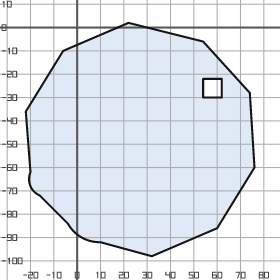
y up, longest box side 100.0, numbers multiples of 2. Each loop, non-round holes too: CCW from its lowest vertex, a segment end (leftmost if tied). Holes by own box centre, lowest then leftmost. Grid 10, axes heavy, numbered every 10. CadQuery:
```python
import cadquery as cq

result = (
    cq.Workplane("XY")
    .moveTo(32.0, -98.0)
    .lineTo(60.0, -86.0)
    .lineTo(76.0, -60.0)
    .lineTo(74.0, -28.0)
    .lineTo(54.0, -6.0)
    .lineTo(22.0, 2.0)
    .lineTo(-6.0, -10.0)
    .lineTo(-22.0, -36.0)
    .lineTo(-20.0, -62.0)
    .threePointArc((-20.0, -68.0), (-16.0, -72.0))
    .lineTo(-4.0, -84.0)
    .threePointArc((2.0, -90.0), (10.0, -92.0))
    .close()
    .moveTo(54.0, -30.0)
    .lineTo(62.0, -30.0)
    .lineTo(62.0, -22.0)
    .lineTo(54.0, -22.0)
    .close()
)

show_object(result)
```